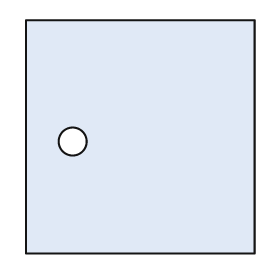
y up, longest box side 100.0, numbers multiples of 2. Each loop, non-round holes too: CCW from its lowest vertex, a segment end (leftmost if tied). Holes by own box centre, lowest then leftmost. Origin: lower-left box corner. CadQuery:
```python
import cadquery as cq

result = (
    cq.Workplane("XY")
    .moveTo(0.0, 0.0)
    .lineTo(98.0, 0.0)
    .lineTo(98.0, 100.0)
    .lineTo(0.0, 100.0)
    .close()
    .moveTo(20.0, 48.0)
    .circle(6.0)
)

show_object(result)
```